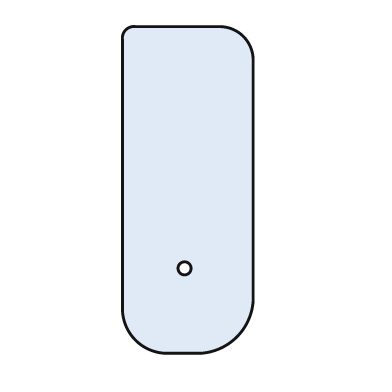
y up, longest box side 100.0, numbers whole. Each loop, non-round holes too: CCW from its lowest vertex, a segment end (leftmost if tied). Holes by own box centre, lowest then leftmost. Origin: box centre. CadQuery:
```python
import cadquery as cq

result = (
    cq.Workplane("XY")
    .moveTo(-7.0, -50.0)
    .lineTo(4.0, -50.0)
    .threePointArc((15.0, -45.0), (20.0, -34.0))
    .lineTo(20.0, 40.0)
    .threePointArc((17.0, 47.0), (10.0, 50.0))
    .lineTo(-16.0, 50.0)
    .threePointArc((-19.0, 49.0), (-20.0, 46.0))
    .lineTo(-20.0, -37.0)
    .threePointArc((-16.0, -46.0), (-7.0, -50.0))
    .close()
    .moveTo(-1.0, -24.0)
    .circle(2.0)
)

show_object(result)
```